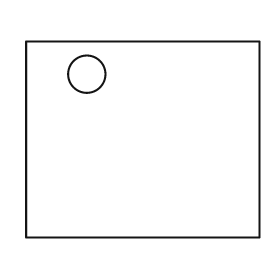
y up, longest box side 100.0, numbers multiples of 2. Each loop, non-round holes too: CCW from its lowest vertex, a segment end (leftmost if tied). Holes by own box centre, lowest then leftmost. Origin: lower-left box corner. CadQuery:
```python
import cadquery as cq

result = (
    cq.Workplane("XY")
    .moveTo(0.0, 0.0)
    .lineTo(100.0, 0.0)
    .lineTo(100.0, 84.0)
    .lineTo(0.0, 84.0)
    .close()
    .moveTo(26.0, 70.0)
    .circle(8.0)
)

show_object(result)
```